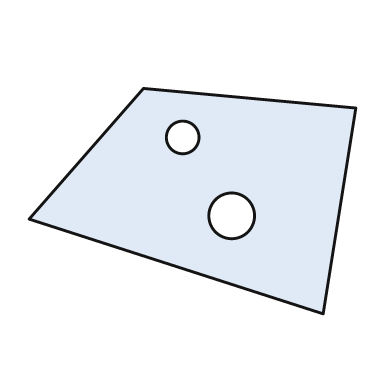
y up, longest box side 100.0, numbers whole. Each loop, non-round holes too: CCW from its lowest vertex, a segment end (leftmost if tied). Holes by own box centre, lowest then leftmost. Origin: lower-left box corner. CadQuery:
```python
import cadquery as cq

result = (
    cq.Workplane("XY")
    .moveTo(90.0, 0.0)
    .lineTo(100.0, 63.0)
    .lineTo(35.0, 69.0)
    .lineTo(0.0, 29.0)
    .close()
    .moveTo(62.0, 30.0)
    .circle(7.0)
    .moveTo(47.0, 54.0)
    .circle(5.0)
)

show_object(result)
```